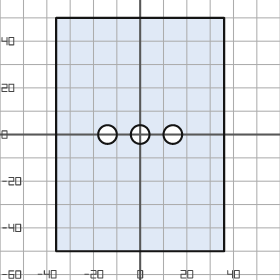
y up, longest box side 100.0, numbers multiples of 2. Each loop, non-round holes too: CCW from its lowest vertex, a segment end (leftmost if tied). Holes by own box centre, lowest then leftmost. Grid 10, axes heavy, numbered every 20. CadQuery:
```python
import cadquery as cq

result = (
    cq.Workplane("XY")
    .moveTo(-36.0, -50.0)
    .lineTo(36.0, -50.0)
    .lineTo(36.0, 50.0)
    .lineTo(-36.0, 50.0)
    .close()
    .moveTo(-14.0, 0.0)
    .circle(4.0)
    .moveTo(0.0, 0.0)
    .circle(4.0)
    .moveTo(14.0, 0.0)
    .circle(4.0)
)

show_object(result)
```